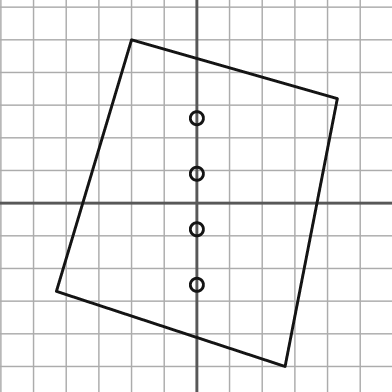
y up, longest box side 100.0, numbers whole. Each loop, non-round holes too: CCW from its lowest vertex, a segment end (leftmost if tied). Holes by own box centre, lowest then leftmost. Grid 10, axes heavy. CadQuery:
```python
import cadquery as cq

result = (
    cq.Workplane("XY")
    .moveTo(27.0, -50.0)
    .lineTo(43.0, 32.0)
    .lineTo(-20.0, 50.0)
    .lineTo(-43.0, -27.0)
    .close()
    .moveTo(0.0, -25.0)
    .circle(2.0)
    .moveTo(0.0, -8.0)
    .circle(2.0)
    .moveTo(0.0, 9.0)
    .circle(2.0)
    .moveTo(0.0, 26.0)
    .circle(2.0)
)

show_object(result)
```